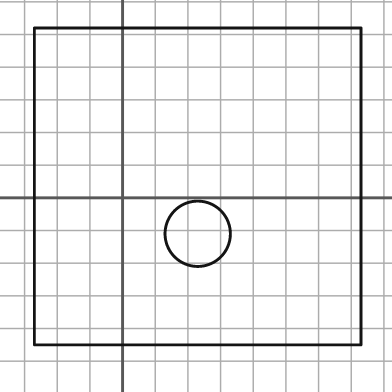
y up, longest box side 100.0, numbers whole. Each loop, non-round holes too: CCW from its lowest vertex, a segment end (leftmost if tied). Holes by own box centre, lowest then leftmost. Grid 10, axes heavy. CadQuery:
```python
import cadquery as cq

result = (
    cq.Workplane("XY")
    .moveTo(-27.0, -45.0)
    .lineTo(73.0, -45.0)
    .lineTo(73.0, 52.0)
    .lineTo(-27.0, 52.0)
    .close()
    .moveTo(23.0, -11.0)
    .circle(10.0)
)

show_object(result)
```